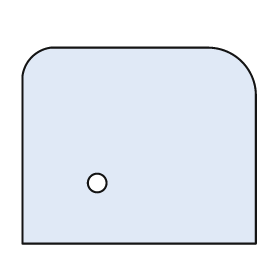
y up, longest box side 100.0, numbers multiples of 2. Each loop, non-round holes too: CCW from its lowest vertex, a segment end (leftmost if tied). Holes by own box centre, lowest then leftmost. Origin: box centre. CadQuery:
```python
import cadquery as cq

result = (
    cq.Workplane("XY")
    .moveTo(-50.0, -42.0)
    .lineTo(50.0, -42.0)
    .lineTo(50.0, 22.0)
    .threePointArc((44.0, 36.0), (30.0, 42.0))
    .lineTo(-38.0, 42.0)
    .threePointArc((-46.0, 38.0), (-50.0, 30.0))
    .close()
    .moveTo(-18.0, -16.0)
    .circle(4.0)
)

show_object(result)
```